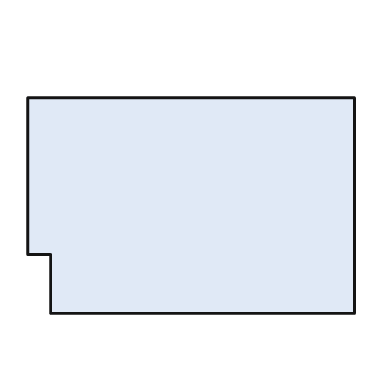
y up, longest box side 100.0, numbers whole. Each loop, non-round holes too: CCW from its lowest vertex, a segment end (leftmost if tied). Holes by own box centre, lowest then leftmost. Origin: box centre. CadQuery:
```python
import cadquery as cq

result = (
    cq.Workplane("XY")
    .moveTo(-43.0, -33.0)
    .lineTo(50.0, -33.0)
    .lineTo(50.0, 33.0)
    .lineTo(-50.0, 33.0)
    .lineTo(-50.0, -15.0)
    .lineTo(-43.0, -15.0)
    .close()
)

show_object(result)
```